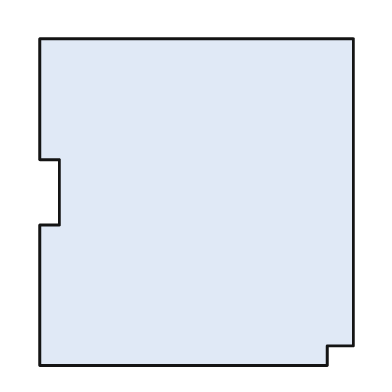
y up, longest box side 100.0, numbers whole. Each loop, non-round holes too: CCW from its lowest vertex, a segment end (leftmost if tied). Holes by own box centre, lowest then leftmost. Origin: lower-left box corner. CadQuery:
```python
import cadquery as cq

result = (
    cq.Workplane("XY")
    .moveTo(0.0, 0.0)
    .lineTo(88.0, 0.0)
    .lineTo(88.0, 6.0)
    .lineTo(96.0, 6.0)
    .lineTo(96.0, 100.0)
    .lineTo(0.0, 100.0)
    .lineTo(0.0, 63.0)
    .lineTo(6.0, 63.0)
    .lineTo(6.0, 43.0)
    .lineTo(0.0, 43.0)
    .close()
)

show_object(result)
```